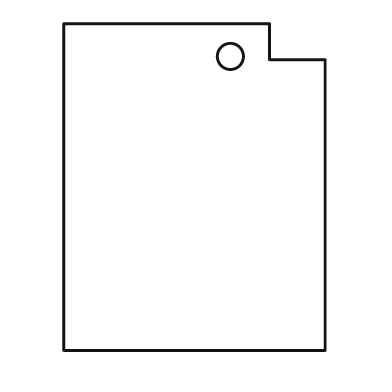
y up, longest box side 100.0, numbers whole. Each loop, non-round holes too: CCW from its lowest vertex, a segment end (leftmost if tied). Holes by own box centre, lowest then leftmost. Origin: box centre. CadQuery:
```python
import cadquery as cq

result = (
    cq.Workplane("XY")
    .moveTo(-40.0, -50.0)
    .lineTo(40.0, -50.0)
    .lineTo(40.0, 39.0)
    .lineTo(23.0, 39.0)
    .lineTo(23.0, 50.0)
    .lineTo(-40.0, 50.0)
    .close()
    .moveTo(11.0, 40.0)
    .circle(4.0)
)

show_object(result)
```